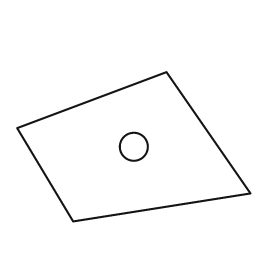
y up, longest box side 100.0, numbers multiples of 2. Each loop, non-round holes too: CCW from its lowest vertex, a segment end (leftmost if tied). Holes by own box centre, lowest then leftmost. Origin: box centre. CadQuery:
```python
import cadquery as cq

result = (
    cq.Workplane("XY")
    .moveTo(-26.0, -32.0)
    .lineTo(50.0, -20.0)
    .lineTo(14.0, 32.0)
    .lineTo(-50.0, 8.0)
    .close()
    .moveTo(0.0, 0.0)
    .circle(6.0)
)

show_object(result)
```